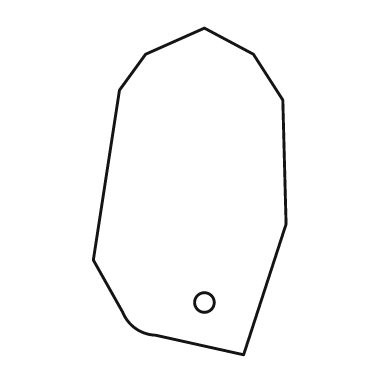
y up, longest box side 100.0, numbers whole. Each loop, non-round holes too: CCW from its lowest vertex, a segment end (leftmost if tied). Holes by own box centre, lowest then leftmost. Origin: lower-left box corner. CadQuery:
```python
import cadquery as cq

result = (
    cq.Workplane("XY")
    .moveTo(46.0, 0.0)
    .lineTo(59.0, 40.0)
    .lineTo(58.0, 78.0)
    .lineTo(49.0, 92.0)
    .lineTo(34.0, 100.0)
    .lineTo(16.0, 92.0)
    .lineTo(8.0, 81.0)
    .lineTo(0.0, 29.0)
    .lineTo(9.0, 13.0)
    .threePointArc((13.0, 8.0), (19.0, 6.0))
    .close()
    .moveTo(34.0, 16.0)
    .circle(3.0)
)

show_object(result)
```